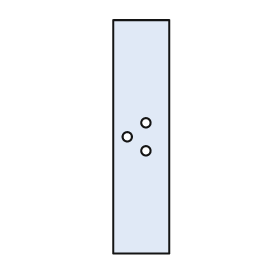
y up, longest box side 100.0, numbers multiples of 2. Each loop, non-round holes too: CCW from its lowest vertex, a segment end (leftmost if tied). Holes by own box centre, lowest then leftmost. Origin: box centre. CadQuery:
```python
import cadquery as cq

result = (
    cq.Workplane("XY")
    .moveTo(-12.0, -50.0)
    .lineTo(12.0, -50.0)
    .lineTo(12.0, 50.0)
    .lineTo(-12.0, 50.0)
    .close()
    .moveTo(2.0, -6.0)
    .circle(2.0)
    .moveTo(-6.0, 0.0)
    .circle(2.0)
    .moveTo(2.0, 6.0)
    .circle(2.0)
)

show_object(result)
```